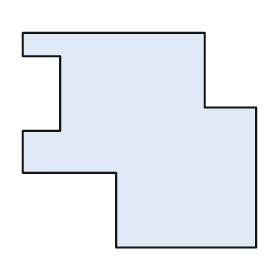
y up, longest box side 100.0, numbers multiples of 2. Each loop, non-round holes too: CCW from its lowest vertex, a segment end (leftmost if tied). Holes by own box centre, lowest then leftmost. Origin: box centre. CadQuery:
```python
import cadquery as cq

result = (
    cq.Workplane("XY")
    .moveTo(-10.0, -46.0)
    .lineTo(50.0, -46.0)
    .lineTo(50.0, 14.0)
    .lineTo(28.0, 14.0)
    .lineTo(28.0, 46.0)
    .lineTo(-50.0, 46.0)
    .lineTo(-50.0, 36.0)
    .lineTo(-34.0, 36.0)
    .lineTo(-34.0, 4.0)
    .lineTo(-50.0, 4.0)
    .lineTo(-50.0, -14.0)
    .lineTo(-10.0, -14.0)
    .close()
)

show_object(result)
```